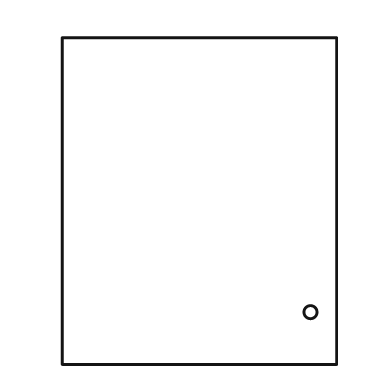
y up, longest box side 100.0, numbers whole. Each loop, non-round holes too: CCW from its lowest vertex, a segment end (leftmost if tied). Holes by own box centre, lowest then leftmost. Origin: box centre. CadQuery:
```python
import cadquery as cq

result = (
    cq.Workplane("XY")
    .moveTo(-42.0, -50.0)
    .lineTo(42.0, -50.0)
    .lineTo(42.0, 50.0)
    .lineTo(-42.0, 50.0)
    .close()
    .moveTo(34.0, -34.0)
    .circle(2.0)
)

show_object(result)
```